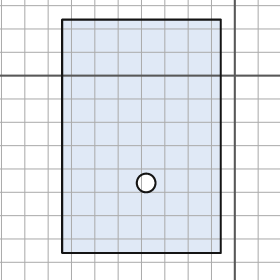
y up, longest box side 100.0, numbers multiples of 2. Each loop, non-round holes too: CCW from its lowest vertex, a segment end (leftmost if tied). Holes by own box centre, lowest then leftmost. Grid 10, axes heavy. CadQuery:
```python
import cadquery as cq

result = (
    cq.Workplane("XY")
    .moveTo(-74.0, -76.0)
    .lineTo(-6.0, -76.0)
    .lineTo(-6.0, 24.0)
    .lineTo(-74.0, 24.0)
    .close()
    .moveTo(-38.0, -46.0)
    .circle(4.0)
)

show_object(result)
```